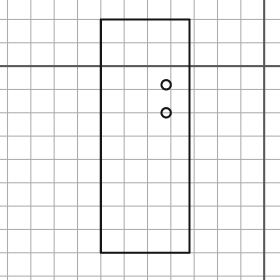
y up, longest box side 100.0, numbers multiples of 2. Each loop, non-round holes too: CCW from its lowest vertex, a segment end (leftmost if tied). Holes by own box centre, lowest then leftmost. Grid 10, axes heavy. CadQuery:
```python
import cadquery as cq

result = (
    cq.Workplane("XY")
    .moveTo(-70.0, -80.0)
    .lineTo(-32.0, -80.0)
    .lineTo(-32.0, 20.0)
    .lineTo(-70.0, 20.0)
    .close()
    .moveTo(-42.0, -20.0)
    .circle(2.0)
    .moveTo(-42.0, -8.0)
    .circle(2.0)
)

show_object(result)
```